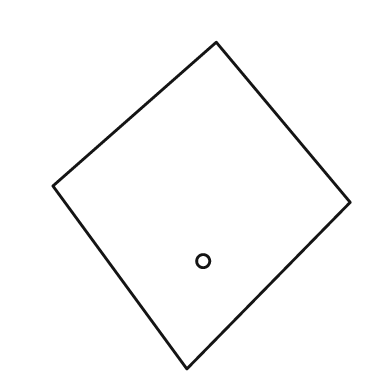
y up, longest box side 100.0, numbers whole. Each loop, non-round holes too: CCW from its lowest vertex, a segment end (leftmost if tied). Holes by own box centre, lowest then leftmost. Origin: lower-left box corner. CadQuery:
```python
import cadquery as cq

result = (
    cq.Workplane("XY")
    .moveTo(41.0, 0.0)
    .lineTo(91.0, 51.0)
    .lineTo(50.0, 100.0)
    .lineTo(0.0, 56.0)
    .close()
    .moveTo(46.0, 33.0)
    .circle(2.0)
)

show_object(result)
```